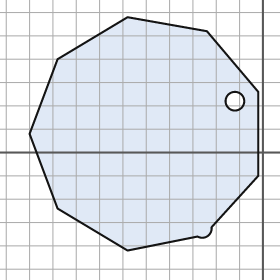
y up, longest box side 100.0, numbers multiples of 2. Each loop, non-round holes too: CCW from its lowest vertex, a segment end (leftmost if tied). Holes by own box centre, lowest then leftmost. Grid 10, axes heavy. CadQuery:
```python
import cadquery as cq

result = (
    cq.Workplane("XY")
    .moveTo(-58.0, -42.0)
    .lineTo(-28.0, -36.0)
    .threePointArc((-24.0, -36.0), (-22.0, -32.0))
    .lineTo(-2.0, -10.0)
    .lineTo(-2.0, 26.0)
    .lineTo(-24.0, 52.0)
    .lineTo(-58.0, 58.0)
    .lineTo(-88.0, 40.0)
    .lineTo(-100.0, 8.0)
    .lineTo(-88.0, -24.0)
    .close()
    .moveTo(-12.0, 22.0)
    .circle(4.0)
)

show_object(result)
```